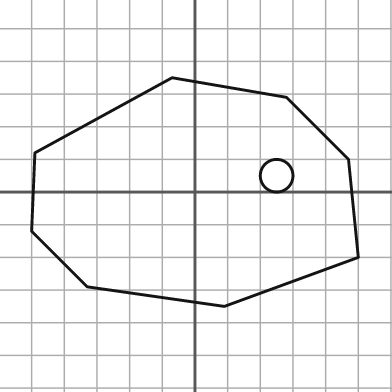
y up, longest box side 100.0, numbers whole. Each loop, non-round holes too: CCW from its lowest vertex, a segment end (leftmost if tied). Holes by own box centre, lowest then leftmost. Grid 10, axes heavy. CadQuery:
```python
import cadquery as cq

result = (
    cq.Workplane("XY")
    .moveTo(9.0, -35.0)
    .lineTo(50.0, -20.0)
    .lineTo(47.0, 10.0)
    .lineTo(28.0, 29.0)
    .lineTo(-7.0, 35.0)
    .lineTo(-49.0, 12.0)
    .lineTo(-50.0, -12.0)
    .lineTo(-33.0, -29.0)
    .close()
    .moveTo(25.0, 5.0)
    .circle(5.0)
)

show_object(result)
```